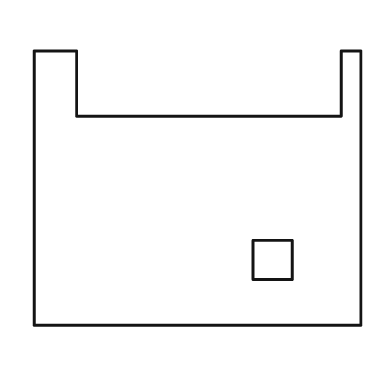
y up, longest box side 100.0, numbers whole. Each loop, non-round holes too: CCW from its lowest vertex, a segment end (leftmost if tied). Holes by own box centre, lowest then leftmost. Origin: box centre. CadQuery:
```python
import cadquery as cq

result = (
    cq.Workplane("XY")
    .moveTo(-50.0, -42.0)
    .lineTo(50.0, -42.0)
    .lineTo(50.0, 42.0)
    .lineTo(44.0, 42.0)
    .lineTo(44.0, 22.0)
    .lineTo(-37.0, 22.0)
    .lineTo(-37.0, 42.0)
    .lineTo(-50.0, 42.0)
    .close()
    .moveTo(17.0, -28.0)
    .lineTo(29.0, -28.0)
    .lineTo(29.0, -16.0)
    .lineTo(17.0, -16.0)
    .close()
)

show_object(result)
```